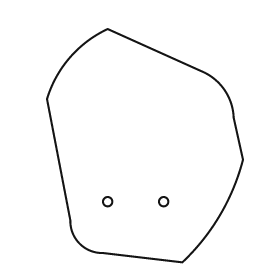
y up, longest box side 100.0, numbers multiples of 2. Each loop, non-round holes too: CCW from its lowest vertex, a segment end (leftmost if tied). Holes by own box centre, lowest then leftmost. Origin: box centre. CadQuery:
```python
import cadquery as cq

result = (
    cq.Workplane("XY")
    .moveTo(16.0, -50.0)
    .threePointArc((32.0, -30.0), (42.0, -6.0))
    .lineTo(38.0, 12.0)
    .threePointArc((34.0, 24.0), (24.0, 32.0))
    .lineTo(-16.0, 50.0)
    .threePointArc((-32.0, 38.0), (-42.0, 20.0))
    .lineTo(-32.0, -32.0)
    .threePointArc((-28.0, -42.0), (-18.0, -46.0))
    .close()
    .moveTo(-16.0, -24.0)
    .circle(2.0)
    .moveTo(8.0, -24.0)
    .circle(2.0)
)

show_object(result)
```